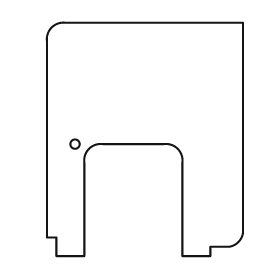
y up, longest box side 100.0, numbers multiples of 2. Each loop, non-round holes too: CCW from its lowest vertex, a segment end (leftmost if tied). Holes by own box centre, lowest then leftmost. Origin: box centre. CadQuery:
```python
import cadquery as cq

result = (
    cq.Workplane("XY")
    .moveTo(-38.0, -50.0)
    .lineTo(-26.0, -50.0)
    .lineTo(-26.0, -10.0)
    .threePointArc((-24.0, -4.0), (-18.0, -2.0))
    .lineTo(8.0, -2.0)
    .threePointArc((14.0, -4.0), (16.0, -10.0))
    .lineTo(16.0, -50.0)
    .lineTo(28.0, -50.0)
    .lineTo(28.0, -46.0)
    .lineTo(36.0, -46.0)
    .threePointArc((40.0, -44.0), (42.0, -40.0))
    .lineTo(42.0, 50.0)
    .lineTo(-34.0, 50.0)
    .threePointArc((-40.0, 48.0), (-42.0, 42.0))
    .lineTo(-42.0, -42.0)
    .lineTo(-38.0, -42.0)
    .close()
    .moveTo(-30.0, -2.0)
    .circle(2.0)
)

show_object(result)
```